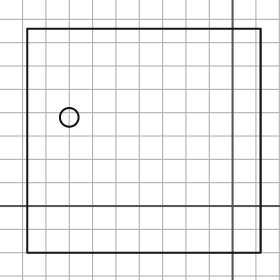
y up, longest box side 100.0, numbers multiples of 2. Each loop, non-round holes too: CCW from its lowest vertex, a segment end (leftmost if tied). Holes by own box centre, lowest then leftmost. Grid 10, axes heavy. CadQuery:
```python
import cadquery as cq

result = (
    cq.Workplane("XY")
    .moveTo(-88.0, -20.0)
    .lineTo(12.0, -20.0)
    .lineTo(12.0, 76.0)
    .lineTo(-88.0, 76.0)
    .close()
    .moveTo(-70.0, 38.0)
    .circle(4.0)
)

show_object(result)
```